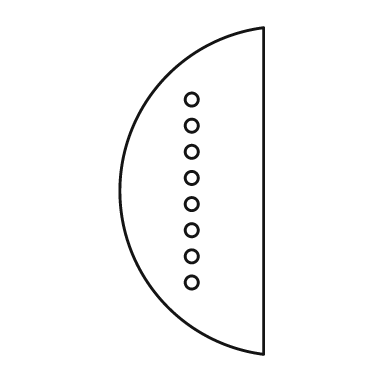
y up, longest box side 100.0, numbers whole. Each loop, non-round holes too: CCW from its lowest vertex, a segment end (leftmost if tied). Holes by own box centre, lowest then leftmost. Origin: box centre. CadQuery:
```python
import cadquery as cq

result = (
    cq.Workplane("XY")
    .moveTo(22.0, -50.0)
    .lineTo(22.0, 50.0)
    .threePointArc((-22.0, 0.0), (22.0, -50.0))
    .close()
    .moveTo(0.0, -28.0)
    .circle(2.0)
    .moveTo(0.0, -20.0)
    .circle(2.0)
    .moveTo(0.0, -12.0)
    .circle(2.0)
    .moveTo(0.0, -4.0)
    .circle(2.0)
    .moveTo(0.0, 4.0)
    .circle(2.0)
    .moveTo(0.0, 12.0)
    .circle(2.0)
    .moveTo(0.0, 20.0)
    .circle(2.0)
    .moveTo(0.0, 28.0)
    .circle(2.0)
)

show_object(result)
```